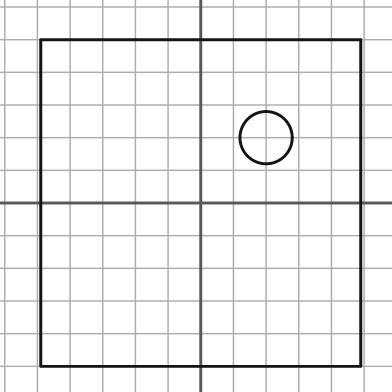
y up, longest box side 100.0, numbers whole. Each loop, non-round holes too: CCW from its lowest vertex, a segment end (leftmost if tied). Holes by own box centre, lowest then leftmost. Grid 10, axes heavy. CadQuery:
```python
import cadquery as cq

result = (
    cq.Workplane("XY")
    .moveTo(-49.0, -50.0)
    .lineTo(49.0, -50.0)
    .lineTo(49.0, 50.0)
    .lineTo(-49.0, 50.0)
    .close()
    .moveTo(20.0, 20.0)
    .circle(8.0)
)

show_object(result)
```